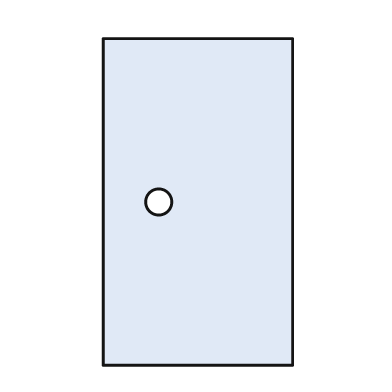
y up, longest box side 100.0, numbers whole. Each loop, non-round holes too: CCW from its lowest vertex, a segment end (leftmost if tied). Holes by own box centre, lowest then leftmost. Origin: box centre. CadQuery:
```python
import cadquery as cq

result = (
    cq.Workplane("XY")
    .moveTo(-29.0, -50.0)
    .lineTo(29.0, -50.0)
    .lineTo(29.0, 50.0)
    .lineTo(-29.0, 50.0)
    .close()
    .moveTo(-12.0, 0.0)
    .circle(4.0)
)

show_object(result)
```